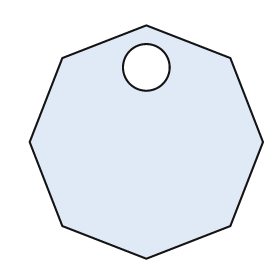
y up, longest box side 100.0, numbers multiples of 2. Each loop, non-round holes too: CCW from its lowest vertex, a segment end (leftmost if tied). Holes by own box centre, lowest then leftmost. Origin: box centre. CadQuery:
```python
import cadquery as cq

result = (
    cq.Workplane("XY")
    .moveTo(0.0, -50.0)
    .lineTo(36.0, -36.0)
    .lineTo(50.0, 0.0)
    .lineTo(36.0, 36.0)
    .lineTo(0.0, 50.0)
    .lineTo(-36.0, 36.0)
    .lineTo(-50.0, 0.0)
    .lineTo(-36.0, -36.0)
    .close()
    .moveTo(0.0, 32.0)
    .circle(10.0)
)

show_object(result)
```